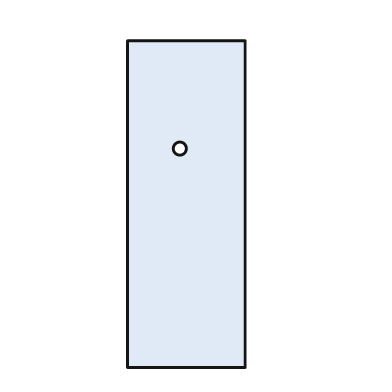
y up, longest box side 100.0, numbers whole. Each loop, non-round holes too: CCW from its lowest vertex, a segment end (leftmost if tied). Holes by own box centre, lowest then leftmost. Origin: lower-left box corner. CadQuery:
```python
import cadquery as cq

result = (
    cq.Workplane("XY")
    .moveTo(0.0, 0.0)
    .lineTo(36.0, 0.0)
    .lineTo(36.0, 100.0)
    .lineTo(0.0, 100.0)
    .close()
    .moveTo(16.0, 67.0)
    .circle(2.0)
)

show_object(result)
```